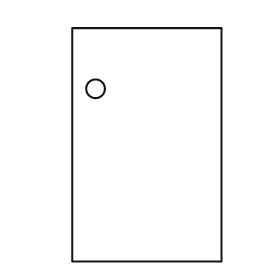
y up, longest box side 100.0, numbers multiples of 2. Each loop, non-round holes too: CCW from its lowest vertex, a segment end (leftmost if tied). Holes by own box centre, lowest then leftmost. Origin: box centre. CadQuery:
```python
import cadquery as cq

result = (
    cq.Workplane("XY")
    .moveTo(-32.0, -50.0)
    .lineTo(32.0, -50.0)
    .lineTo(32.0, 50.0)
    .lineTo(-32.0, 50.0)
    .close()
    .moveTo(-22.0, 24.0)
    .circle(4.0)
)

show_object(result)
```